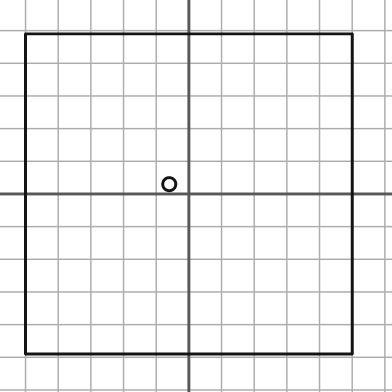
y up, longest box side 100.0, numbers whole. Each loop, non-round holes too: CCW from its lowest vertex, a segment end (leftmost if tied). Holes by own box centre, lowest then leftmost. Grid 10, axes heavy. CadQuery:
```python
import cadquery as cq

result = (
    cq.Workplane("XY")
    .moveTo(-50.0, -49.0)
    .lineTo(50.0, -49.0)
    .lineTo(50.0, 49.0)
    .lineTo(-50.0, 49.0)
    .close()
    .moveTo(-6.0, 3.0)
    .circle(2.0)
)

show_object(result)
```